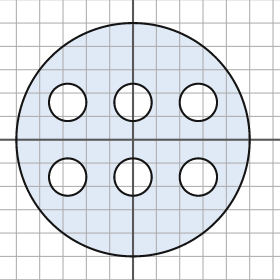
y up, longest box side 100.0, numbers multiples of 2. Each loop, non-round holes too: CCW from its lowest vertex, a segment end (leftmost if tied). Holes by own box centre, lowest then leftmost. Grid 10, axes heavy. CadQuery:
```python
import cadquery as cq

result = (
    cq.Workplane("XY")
    .moveTo(0.0, 0.0)
    .circle(50.0)
    .moveTo(-28.0, -16.0)
    .circle(8.0)
    .moveTo(0.0, -16.0)
    .circle(8.0)
    .moveTo(28.0, -16.0)
    .circle(8.0)
    .moveTo(-28.0, 16.0)
    .circle(8.0)
    .moveTo(0.0, 16.0)
    .circle(8.0)
    .moveTo(28.0, 16.0)
    .circle(8.0)
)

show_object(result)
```